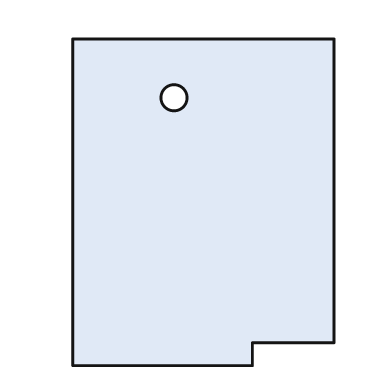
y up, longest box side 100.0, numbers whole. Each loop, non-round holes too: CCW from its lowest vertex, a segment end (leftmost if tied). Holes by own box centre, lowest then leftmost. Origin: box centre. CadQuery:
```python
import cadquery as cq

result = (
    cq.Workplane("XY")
    .moveTo(-40.0, -50.0)
    .lineTo(15.0, -50.0)
    .lineTo(15.0, -43.0)
    .lineTo(40.0, -43.0)
    .lineTo(40.0, 50.0)
    .lineTo(-40.0, 50.0)
    .close()
    .moveTo(-9.0, 32.0)
    .circle(4.0)
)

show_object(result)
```